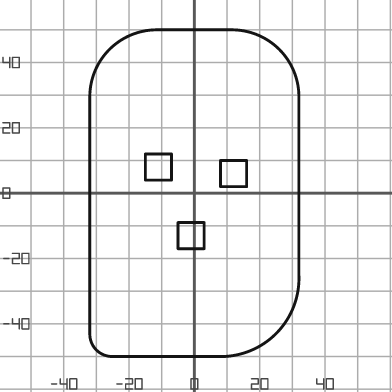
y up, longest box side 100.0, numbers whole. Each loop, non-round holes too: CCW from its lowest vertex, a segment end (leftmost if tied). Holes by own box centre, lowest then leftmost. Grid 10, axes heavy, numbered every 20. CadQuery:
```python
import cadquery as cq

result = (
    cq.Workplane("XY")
    .moveTo(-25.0, -50.0)
    .lineTo(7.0, -50.0)
    .threePointArc((25.0, -43.0), (32.0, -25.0))
    .lineTo(32.0, 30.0)
    .threePointArc((26.0, 44.0), (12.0, 50.0))
    .lineTo(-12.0, 50.0)
    .threePointArc((-26.0, 44.0), (-32.0, 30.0))
    .lineTo(-32.0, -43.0)
    .threePointArc((-30.0, -48.0), (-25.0, -50.0))
    .close()
    .moveTo(-5.0, -17.0)
    .lineTo(3.0, -17.0)
    .lineTo(3.0, -9.0)
    .lineTo(-5.0, -9.0)
    .close()
    .moveTo(8.0, 2.0)
    .lineTo(16.0, 2.0)
    .lineTo(16.0, 10.0)
    .lineTo(8.0, 10.0)
    .close()
    .moveTo(-15.0, 4.0)
    .lineTo(-7.0, 4.0)
    .lineTo(-7.0, 12.0)
    .lineTo(-15.0, 12.0)
    .close()
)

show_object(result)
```